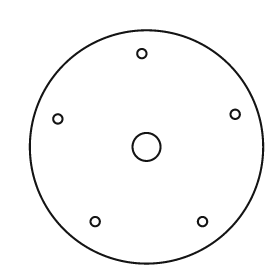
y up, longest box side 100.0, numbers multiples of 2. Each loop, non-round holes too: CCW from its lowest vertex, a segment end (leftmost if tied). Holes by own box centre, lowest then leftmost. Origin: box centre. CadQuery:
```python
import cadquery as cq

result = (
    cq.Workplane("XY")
    .moveTo(0.0, 0.0)
    .circle(50.0)
    .moveTo(-22.0, -32.0)
    .circle(2.0)
    .moveTo(24.0, -32.0)
    .circle(2.0)
    .moveTo(0.0, 0.0)
    .circle(6.0)
    .moveTo(-38.0, 12.0)
    .circle(2.0)
    .moveTo(38.0, 14.0)
    .circle(2.0)
    .moveTo(-2.0, 40.0)
    .circle(2.0)
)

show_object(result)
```